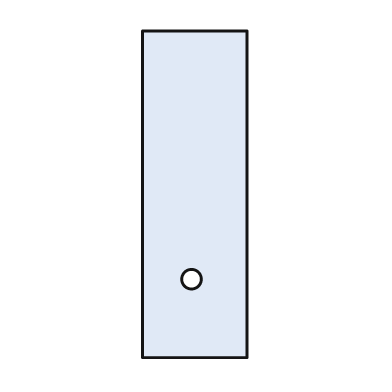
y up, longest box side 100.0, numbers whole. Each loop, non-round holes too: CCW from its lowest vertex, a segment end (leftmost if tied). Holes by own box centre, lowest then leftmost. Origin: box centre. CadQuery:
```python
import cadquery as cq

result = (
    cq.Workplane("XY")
    .moveTo(-16.0, -50.0)
    .lineTo(16.0, -50.0)
    .lineTo(16.0, 50.0)
    .lineTo(-16.0, 50.0)
    .close()
    .moveTo(-1.0, -26.0)
    .circle(3.0)
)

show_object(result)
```